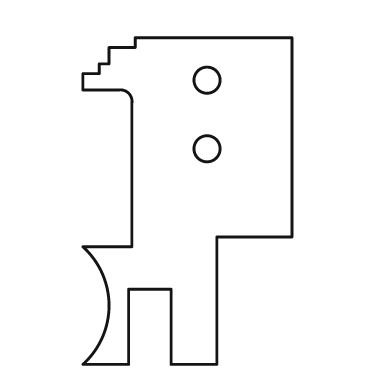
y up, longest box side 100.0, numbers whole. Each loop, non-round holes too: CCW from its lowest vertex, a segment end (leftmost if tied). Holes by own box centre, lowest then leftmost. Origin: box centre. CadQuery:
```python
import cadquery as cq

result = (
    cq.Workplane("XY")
    .moveTo(-32.0, -50.0)
    .lineTo(-18.0, -50.0)
    .lineTo(-18.0, -27.0)
    .lineTo(-5.0, -27.0)
    .lineTo(-5.0, -50.0)
    .lineTo(9.0, -50.0)
    .lineTo(9.0, -11.0)
    .lineTo(32.0, -11.0)
    .lineTo(32.0, 50.0)
    .lineTo(-16.0, 50.0)
    .lineTo(-16.0, 47.0)
    .lineTo(-24.0, 47.0)
    .lineTo(-24.0, 42.0)
    .lineTo(-27.0, 42.0)
    .lineTo(-27.0, 39.0)
    .lineTo(-32.0, 39.0)
    .lineTo(-32.0, 34.0)
    .lineTo(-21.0, 34.0)
    .threePointArc((-18.0, 33.0), (-17.0, 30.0))
    .lineTo(-17.0, -14.0)
    .lineTo(-32.0, -14.0)
    .threePointArc((-24.0, -32.0), (-32.0, -50.0))
    .close()
    .moveTo(6.0, 16.0)
    .circle(4.0)
    .moveTo(6.0, 37.0)
    .circle(4.0)
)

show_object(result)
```